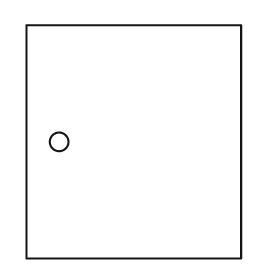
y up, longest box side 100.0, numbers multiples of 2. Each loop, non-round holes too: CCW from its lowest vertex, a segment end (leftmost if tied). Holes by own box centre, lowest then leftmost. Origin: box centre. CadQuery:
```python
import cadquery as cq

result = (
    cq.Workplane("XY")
    .moveTo(-46.0, -50.0)
    .lineTo(46.0, -50.0)
    .lineTo(46.0, 50.0)
    .lineTo(-46.0, 50.0)
    .close()
    .moveTo(-32.0, 0.0)
    .circle(4.0)
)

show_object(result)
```